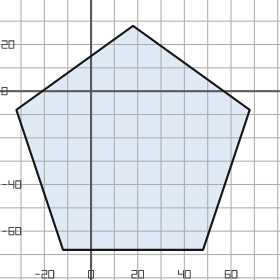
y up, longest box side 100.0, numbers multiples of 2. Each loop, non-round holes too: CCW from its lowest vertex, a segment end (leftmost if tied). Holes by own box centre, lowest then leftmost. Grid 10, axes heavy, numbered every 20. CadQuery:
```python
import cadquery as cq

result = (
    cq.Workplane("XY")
    .moveTo(-12.0, -68.0)
    .lineTo(48.0, -68.0)
    .lineTo(68.0, -8.0)
    .lineTo(18.0, 28.0)
    .lineTo(-32.0, -8.0)
    .close()
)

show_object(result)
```